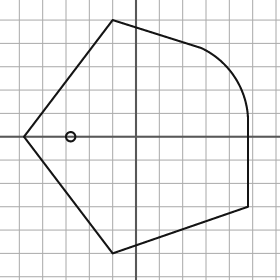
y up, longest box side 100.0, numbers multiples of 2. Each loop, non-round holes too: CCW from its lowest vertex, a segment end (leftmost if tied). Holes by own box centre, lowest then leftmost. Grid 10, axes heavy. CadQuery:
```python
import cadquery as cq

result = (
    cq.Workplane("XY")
    .moveTo(-10.0, -50.0)
    .lineTo(48.0, -30.0)
    .lineTo(48.0, 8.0)
    .threePointArc((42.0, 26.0), (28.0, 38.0))
    .lineTo(-10.0, 50.0)
    .lineTo(-48.0, 0.0)
    .close()
    .moveTo(-28.0, 0.0)
    .circle(2.0)
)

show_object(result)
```